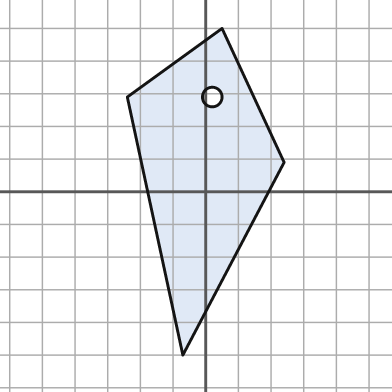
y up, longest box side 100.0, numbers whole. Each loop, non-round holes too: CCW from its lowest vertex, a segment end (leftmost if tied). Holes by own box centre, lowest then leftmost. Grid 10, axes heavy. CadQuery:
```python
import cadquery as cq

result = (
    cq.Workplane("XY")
    .moveTo(-7.0, -50.0)
    .lineTo(24.0, 9.0)
    .lineTo(5.0, 50.0)
    .lineTo(-24.0, 29.0)
    .close()
    .moveTo(2.0, 29.0)
    .circle(3.0)
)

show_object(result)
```